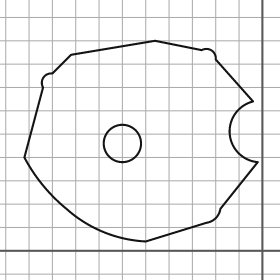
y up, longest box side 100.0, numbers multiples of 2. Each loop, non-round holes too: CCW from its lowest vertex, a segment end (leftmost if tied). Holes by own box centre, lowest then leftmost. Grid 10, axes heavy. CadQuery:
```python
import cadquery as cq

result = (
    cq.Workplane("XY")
    .moveTo(-50.0, 4.0)
    .lineTo(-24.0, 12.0)
    .threePointArc((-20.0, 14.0), (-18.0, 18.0))
    .lineTo(-2.0, 38.0)
    .threePointArc((-14.0, 50.0), (-4.0, 64.0))
    .lineTo(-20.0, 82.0)
    .threePointArc((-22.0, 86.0), (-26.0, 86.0))
    .lineTo(-46.0, 90.0)
    .lineTo(-82.0, 84.0)
    .lineTo(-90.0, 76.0)
    .threePointArc((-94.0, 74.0), (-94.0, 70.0))
    .lineTo(-102.0, 40.0)
    .threePointArc((-94.0, 28.0), (-84.0, 18.0))
    .threePointArc((-68.0, 8.0), (-50.0, 4.0))
    .close()
    .moveTo(-60.0, 46.0)
    .circle(8.0)
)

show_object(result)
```